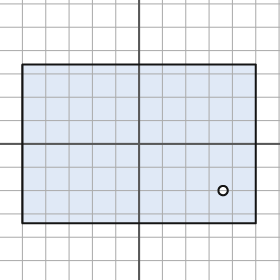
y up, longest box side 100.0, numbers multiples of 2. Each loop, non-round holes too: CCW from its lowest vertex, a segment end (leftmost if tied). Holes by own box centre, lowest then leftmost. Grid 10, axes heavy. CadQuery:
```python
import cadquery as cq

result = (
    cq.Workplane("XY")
    .moveTo(-50.0, -34.0)
    .lineTo(50.0, -34.0)
    .lineTo(50.0, 34.0)
    .lineTo(-50.0, 34.0)
    .close()
    .moveTo(36.0, -20.0)
    .circle(2.0)
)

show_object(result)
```